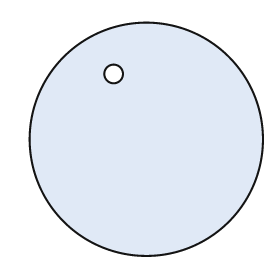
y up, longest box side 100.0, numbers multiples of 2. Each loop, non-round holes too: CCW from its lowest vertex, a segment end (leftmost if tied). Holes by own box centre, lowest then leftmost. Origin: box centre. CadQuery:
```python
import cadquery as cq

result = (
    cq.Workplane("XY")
    .moveTo(0.0, 0.0)
    .circle(50.0)
    .moveTo(-14.0, 28.0)
    .circle(4.0)
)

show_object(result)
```